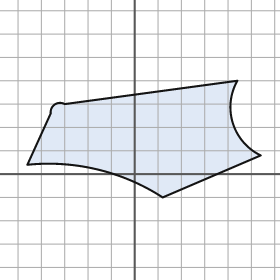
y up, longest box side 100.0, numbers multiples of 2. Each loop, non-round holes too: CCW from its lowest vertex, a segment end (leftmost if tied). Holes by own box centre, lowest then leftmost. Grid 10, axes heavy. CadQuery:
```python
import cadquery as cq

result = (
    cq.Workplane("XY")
    .moveTo(12.0, -10.0)
    .lineTo(54.0, 8.0)
    .threePointArc((42.0, 22.0), (44.0, 40.0))
    .lineTo(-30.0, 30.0)
    .threePointArc((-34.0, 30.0), (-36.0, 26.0))
    .lineTo(-46.0, 4.0)
    .threePointArc((-16.0, 2.0), (12.0, -10.0))
    .close()
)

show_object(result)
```